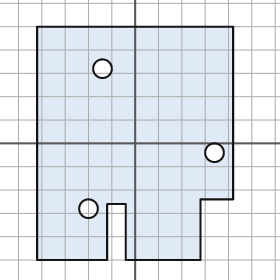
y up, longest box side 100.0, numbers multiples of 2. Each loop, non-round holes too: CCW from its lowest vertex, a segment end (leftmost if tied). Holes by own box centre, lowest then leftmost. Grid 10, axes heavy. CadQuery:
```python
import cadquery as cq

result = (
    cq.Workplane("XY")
    .moveTo(-42.0, -50.0)
    .lineTo(-12.0, -50.0)
    .lineTo(-12.0, -26.0)
    .lineTo(-4.0, -26.0)
    .lineTo(-4.0, -50.0)
    .lineTo(28.0, -50.0)
    .lineTo(28.0, -24.0)
    .lineTo(42.0, -24.0)
    .lineTo(42.0, 50.0)
    .lineTo(-42.0, 50.0)
    .close()
    .moveTo(-20.0, -28.0)
    .circle(4.0)
    .moveTo(34.0, -4.0)
    .circle(4.0)
    .moveTo(-14.0, 32.0)
    .circle(4.0)
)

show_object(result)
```